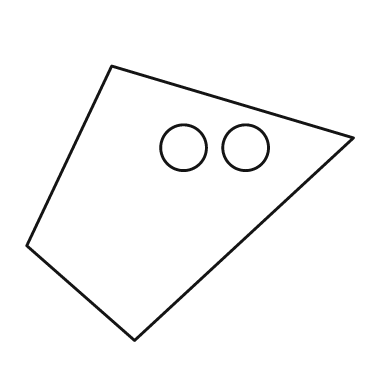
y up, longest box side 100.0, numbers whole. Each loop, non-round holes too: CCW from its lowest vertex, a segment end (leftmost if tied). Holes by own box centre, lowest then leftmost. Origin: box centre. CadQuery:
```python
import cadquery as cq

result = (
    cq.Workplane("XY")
    .moveTo(-17.0, -42.0)
    .lineTo(50.0, 20.0)
    .lineTo(-24.0, 42.0)
    .lineTo(-50.0, -13.0)
    .close()
    .moveTo(-2.0, 17.0)
    .circle(7.0)
    .moveTo(17.0, 17.0)
    .circle(7.0)
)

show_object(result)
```